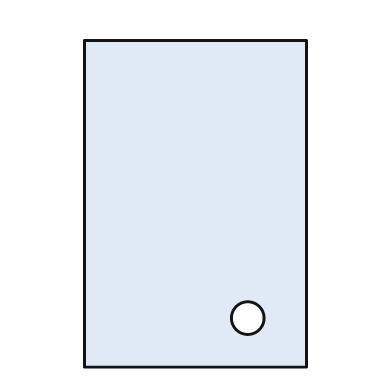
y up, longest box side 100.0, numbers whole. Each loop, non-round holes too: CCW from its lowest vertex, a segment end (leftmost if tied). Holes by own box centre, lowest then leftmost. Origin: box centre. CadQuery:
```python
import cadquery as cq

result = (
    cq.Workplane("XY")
    .moveTo(-34.0, -50.0)
    .lineTo(34.0, -50.0)
    .lineTo(34.0, 50.0)
    .lineTo(-34.0, 50.0)
    .close()
    .moveTo(16.0, -35.0)
    .circle(5.0)
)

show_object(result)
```